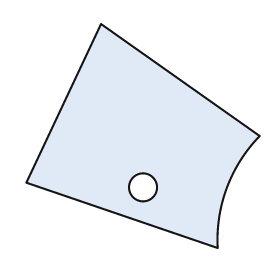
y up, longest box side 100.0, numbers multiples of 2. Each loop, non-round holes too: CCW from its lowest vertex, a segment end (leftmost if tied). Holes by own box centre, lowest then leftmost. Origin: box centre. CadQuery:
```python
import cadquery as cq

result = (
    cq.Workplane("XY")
    .moveTo(32.0, -48.0)
    .threePointArc((36.0, -22.0), (50.0, 0.0))
    .lineTo(-18.0, 48.0)
    .lineTo(-50.0, -20.0)
    .close()
    .moveTo(0.0, -22.0)
    .circle(6.0)
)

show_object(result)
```